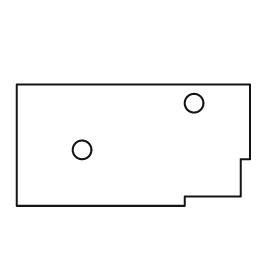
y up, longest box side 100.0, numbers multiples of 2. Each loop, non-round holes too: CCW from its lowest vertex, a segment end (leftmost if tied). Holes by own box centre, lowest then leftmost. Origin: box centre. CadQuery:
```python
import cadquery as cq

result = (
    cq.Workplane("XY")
    .moveTo(-50.0, -26.0)
    .lineTo(22.0, -26.0)
    .lineTo(22.0, -22.0)
    .lineTo(46.0, -22.0)
    .lineTo(46.0, -6.0)
    .lineTo(50.0, -6.0)
    .lineTo(50.0, 26.0)
    .lineTo(-50.0, 26.0)
    .close()
    .moveTo(-22.0, -2.0)
    .circle(4.0)
    .moveTo(26.0, 18.0)
    .circle(4.0)
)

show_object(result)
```